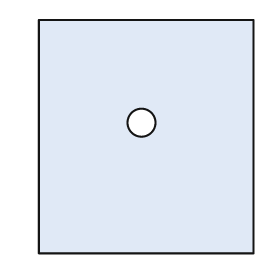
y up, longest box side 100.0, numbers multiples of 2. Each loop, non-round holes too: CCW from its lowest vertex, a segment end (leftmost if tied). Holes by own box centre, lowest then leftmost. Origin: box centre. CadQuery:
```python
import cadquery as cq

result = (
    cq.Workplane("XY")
    .moveTo(-46.0, -50.0)
    .lineTo(46.0, -50.0)
    .lineTo(46.0, 50.0)
    .lineTo(-46.0, 50.0)
    .close()
    .moveTo(-2.0, 6.0)
    .circle(6.0)
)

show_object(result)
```